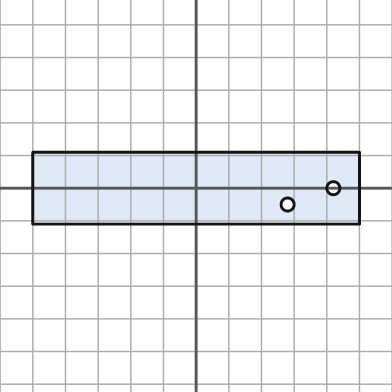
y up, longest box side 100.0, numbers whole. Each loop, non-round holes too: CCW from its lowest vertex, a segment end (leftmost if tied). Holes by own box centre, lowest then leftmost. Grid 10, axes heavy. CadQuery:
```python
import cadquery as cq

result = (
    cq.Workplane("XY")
    .moveTo(-50.0, -11.0)
    .lineTo(50.0, -11.0)
    .lineTo(50.0, 11.0)
    .lineTo(-50.0, 11.0)
    .close()
    .moveTo(28.0, -5.0)
    .circle(2.0)
    .moveTo(42.0, 0.0)
    .circle(2.0)
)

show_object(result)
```